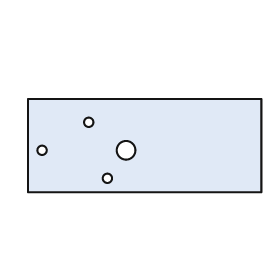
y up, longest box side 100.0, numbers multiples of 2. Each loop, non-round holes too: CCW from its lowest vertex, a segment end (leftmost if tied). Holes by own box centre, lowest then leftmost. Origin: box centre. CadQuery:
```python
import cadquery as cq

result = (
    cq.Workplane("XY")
    .moveTo(-50.0, -20.0)
    .lineTo(50.0, -20.0)
    .lineTo(50.0, 20.0)
    .lineTo(-50.0, 20.0)
    .close()
    .moveTo(-16.0, -14.0)
    .circle(2.0)
    .moveTo(-44.0, -2.0)
    .circle(2.0)
    .moveTo(-8.0, -2.0)
    .circle(4.0)
    .moveTo(-24.0, 10.0)
    .circle(2.0)
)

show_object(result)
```